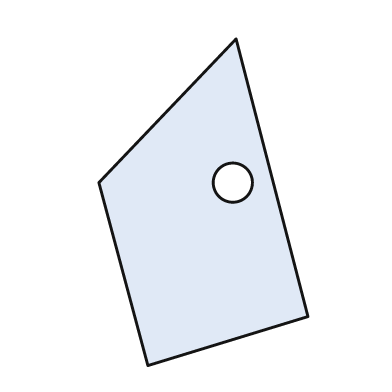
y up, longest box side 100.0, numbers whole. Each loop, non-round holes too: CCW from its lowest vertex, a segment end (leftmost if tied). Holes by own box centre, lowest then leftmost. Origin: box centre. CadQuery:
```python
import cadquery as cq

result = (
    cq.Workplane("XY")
    .moveTo(-17.0, -50.0)
    .lineTo(32.0, -35.0)
    .lineTo(10.0, 50.0)
    .lineTo(-32.0, 6.0)
    .close()
    .moveTo(9.0, 6.0)
    .circle(6.0)
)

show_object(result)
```